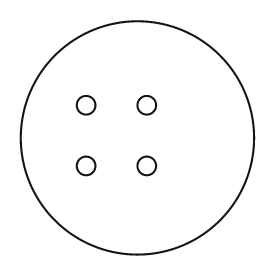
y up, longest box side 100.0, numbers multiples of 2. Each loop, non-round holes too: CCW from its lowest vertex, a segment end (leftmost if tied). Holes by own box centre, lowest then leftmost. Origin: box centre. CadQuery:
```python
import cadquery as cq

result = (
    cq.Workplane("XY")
    .moveTo(0.0, 0.0)
    .circle(50.0)
    .moveTo(-22.0, -12.0)
    .circle(4.0)
    .moveTo(4.0, -12.0)
    .circle(4.0)
    .moveTo(-22.0, 14.0)
    .circle(4.0)
    .moveTo(4.0, 14.0)
    .circle(4.0)
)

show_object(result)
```